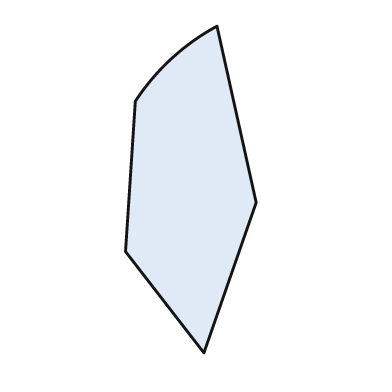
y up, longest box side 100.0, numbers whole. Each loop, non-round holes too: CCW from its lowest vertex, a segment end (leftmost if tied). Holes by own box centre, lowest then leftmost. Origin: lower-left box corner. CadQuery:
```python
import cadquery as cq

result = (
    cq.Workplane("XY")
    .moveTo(24.0, 0.0)
    .lineTo(40.0, 46.0)
    .lineTo(28.0, 100.0)
    .threePointArc((14.0, 90.0), (3.0, 77.0))
    .lineTo(0.0, 31.0)
    .close()
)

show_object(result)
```